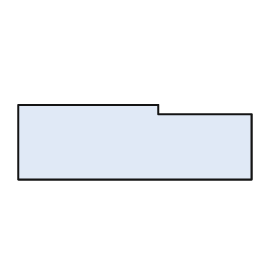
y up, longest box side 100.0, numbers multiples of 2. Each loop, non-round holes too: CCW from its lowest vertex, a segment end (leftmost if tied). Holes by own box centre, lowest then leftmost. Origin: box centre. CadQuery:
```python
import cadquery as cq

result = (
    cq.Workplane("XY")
    .moveTo(-50.0, -16.0)
    .lineTo(50.0, -16.0)
    .lineTo(50.0, 12.0)
    .lineTo(10.0, 12.0)
    .lineTo(10.0, 16.0)
    .lineTo(-50.0, 16.0)
    .close()
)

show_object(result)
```